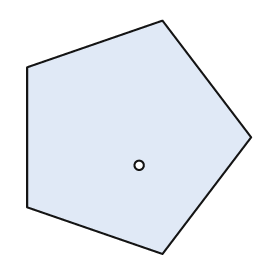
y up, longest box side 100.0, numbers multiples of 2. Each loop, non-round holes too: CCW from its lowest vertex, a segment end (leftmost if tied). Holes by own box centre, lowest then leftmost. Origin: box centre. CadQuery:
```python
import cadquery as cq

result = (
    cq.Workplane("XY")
    .moveTo(10.0, -50.0)
    .lineTo(48.0, 0.0)
    .lineTo(10.0, 50.0)
    .lineTo(-48.0, 30.0)
    .lineTo(-48.0, -30.0)
    .close()
    .moveTo(0.0, -12.0)
    .circle(2.0)
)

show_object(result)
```